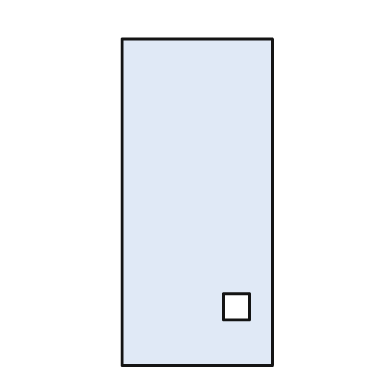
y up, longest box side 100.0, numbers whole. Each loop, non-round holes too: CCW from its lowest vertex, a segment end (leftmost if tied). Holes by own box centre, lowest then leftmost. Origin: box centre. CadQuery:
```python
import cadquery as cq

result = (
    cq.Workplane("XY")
    .moveTo(-23.0, -50.0)
    .lineTo(23.0, -50.0)
    .lineTo(23.0, 50.0)
    .lineTo(-23.0, 50.0)
    .close()
    .moveTo(8.0, -36.0)
    .lineTo(16.0, -36.0)
    .lineTo(16.0, -28.0)
    .lineTo(8.0, -28.0)
    .close()
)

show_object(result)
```